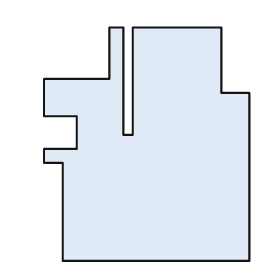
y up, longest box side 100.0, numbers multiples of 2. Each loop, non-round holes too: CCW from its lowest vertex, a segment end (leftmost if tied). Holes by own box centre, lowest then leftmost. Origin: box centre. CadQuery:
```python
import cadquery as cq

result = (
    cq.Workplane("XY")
    .moveTo(-36.0, -50.0)
    .lineTo(44.0, -50.0)
    .lineTo(44.0, 22.0)
    .lineTo(32.0, 22.0)
    .lineTo(32.0, 50.0)
    .lineTo(-6.0, 50.0)
    .lineTo(-6.0, 4.0)
    .lineTo(-10.0, 4.0)
    .lineTo(-10.0, 50.0)
    .lineTo(-16.0, 50.0)
    .lineTo(-16.0, 28.0)
    .lineTo(-44.0, 28.0)
    .lineTo(-44.0, 12.0)
    .lineTo(-30.0, 12.0)
    .lineTo(-30.0, -2.0)
    .lineTo(-44.0, -2.0)
    .lineTo(-44.0, -8.0)
    .lineTo(-36.0, -8.0)
    .close()
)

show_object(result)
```